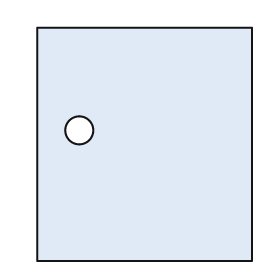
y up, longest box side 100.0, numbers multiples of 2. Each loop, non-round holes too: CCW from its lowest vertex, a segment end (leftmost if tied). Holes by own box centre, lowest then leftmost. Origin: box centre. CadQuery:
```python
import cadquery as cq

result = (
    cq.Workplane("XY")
    .moveTo(-46.0, -50.0)
    .lineTo(46.0, -50.0)
    .lineTo(46.0, 50.0)
    .lineTo(-46.0, 50.0)
    .close()
    .moveTo(-28.0, 6.0)
    .circle(6.0)
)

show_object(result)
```